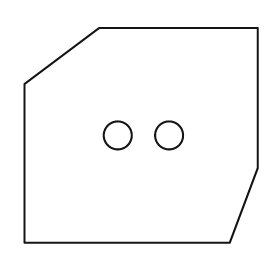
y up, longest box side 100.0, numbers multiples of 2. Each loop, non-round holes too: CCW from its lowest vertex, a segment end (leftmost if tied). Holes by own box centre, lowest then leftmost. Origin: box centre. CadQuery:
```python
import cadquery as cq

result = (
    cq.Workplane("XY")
    .moveTo(-50.0, -46.0)
    .lineTo(38.0, -46.0)
    .lineTo(50.0, -14.0)
    .lineTo(50.0, 46.0)
    .lineTo(-18.0, 46.0)
    .lineTo(-50.0, 22.0)
    .close()
    .moveTo(-10.0, 0.0)
    .circle(6.0)
    .moveTo(12.0, 0.0)
    .circle(6.0)
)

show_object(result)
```